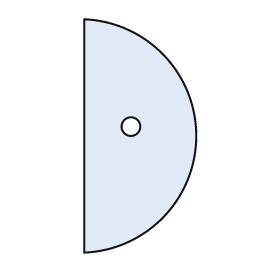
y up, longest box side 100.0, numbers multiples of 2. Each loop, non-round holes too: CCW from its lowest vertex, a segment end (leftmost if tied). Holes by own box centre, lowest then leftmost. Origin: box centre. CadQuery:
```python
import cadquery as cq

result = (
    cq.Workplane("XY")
    .moveTo(-24.0, -50.0)
    .threePointArc((24.0, 0.0), (-24.0, 50.0))
    .close()
    .moveTo(-4.0, 4.0)
    .circle(4.0)
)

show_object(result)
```